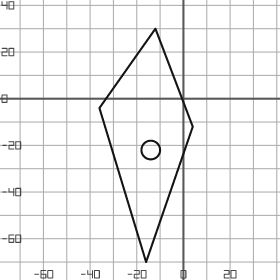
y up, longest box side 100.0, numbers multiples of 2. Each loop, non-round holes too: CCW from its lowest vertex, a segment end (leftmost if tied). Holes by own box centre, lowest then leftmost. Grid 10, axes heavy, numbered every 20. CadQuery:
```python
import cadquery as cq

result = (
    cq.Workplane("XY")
    .moveTo(-16.0, -70.0)
    .lineTo(4.0, -12.0)
    .lineTo(-12.0, 30.0)
    .lineTo(-36.0, -4.0)
    .close()
    .moveTo(-14.0, -22.0)
    .circle(4.0)
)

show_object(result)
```